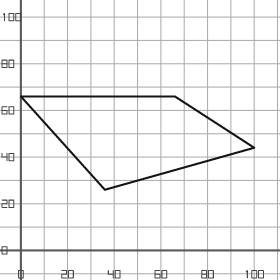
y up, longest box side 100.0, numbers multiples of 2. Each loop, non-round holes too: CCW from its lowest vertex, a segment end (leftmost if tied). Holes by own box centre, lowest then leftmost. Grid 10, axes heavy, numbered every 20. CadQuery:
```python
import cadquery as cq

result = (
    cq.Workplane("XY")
    .moveTo(36.0, 26.0)
    .lineTo(100.0, 44.0)
    .lineTo(66.0, 66.0)
    .lineTo(0.0, 66.0)
    .close()
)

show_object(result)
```